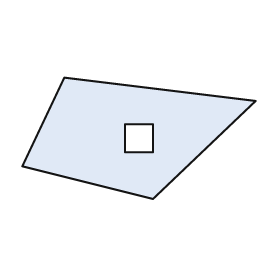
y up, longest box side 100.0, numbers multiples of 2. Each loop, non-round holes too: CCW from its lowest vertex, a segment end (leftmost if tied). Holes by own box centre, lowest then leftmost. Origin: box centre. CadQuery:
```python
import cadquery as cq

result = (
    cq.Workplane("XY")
    .moveTo(6.0, -26.0)
    .lineTo(50.0, 16.0)
    .lineTo(-32.0, 26.0)
    .lineTo(-50.0, -12.0)
    .close()
    .moveTo(-6.0, -6.0)
    .lineTo(6.0, -6.0)
    .lineTo(6.0, 6.0)
    .lineTo(-6.0, 6.0)
    .close()
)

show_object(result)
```